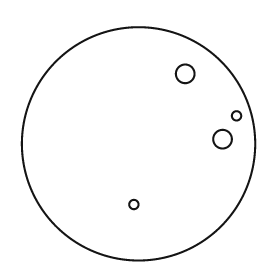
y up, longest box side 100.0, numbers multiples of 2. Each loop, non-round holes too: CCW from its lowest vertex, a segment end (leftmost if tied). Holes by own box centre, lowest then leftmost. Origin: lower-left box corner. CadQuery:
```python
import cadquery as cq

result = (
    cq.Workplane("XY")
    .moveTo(50.0, 50.0)
    .circle(50.0)
    .moveTo(48.0, 24.0)
    .circle(2.0)
    .moveTo(86.0, 52.0)
    .circle(4.0)
    .moveTo(92.0, 62.0)
    .circle(2.0)
    .moveTo(70.0, 80.0)
    .circle(4.0)
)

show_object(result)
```